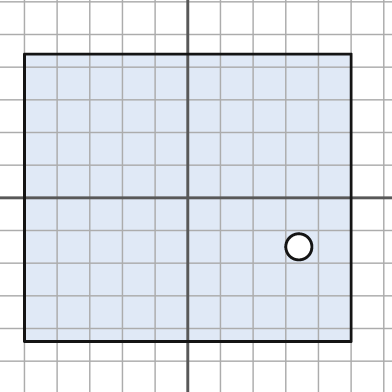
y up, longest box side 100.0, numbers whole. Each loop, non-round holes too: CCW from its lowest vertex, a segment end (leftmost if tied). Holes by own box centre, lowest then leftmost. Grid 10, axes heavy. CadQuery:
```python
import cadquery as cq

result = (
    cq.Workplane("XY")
    .moveTo(-50.0, -44.0)
    .lineTo(50.0, -44.0)
    .lineTo(50.0, 44.0)
    .lineTo(-50.0, 44.0)
    .close()
    .moveTo(34.0, -15.0)
    .circle(4.0)
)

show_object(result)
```